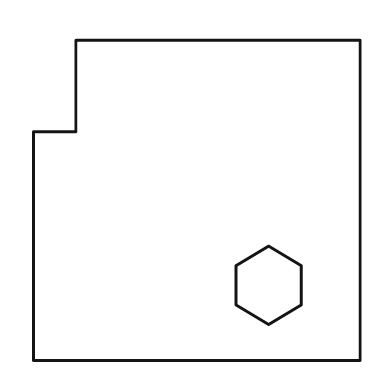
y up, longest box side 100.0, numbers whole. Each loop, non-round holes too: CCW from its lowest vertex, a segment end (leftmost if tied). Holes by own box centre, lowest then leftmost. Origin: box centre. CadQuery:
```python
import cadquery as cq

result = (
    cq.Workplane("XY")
    .moveTo(-50.0, -49.0)
    .lineTo(50.0, -49.0)
    .lineTo(50.0, 49.0)
    .lineTo(-37.0, 49.0)
    .lineTo(-37.0, 21.0)
    .lineTo(-50.0, 21.0)
    .close()
    .moveTo(22.0, -38.0)
    .lineTo(32.0, -32.0)
    .lineTo(32.0, -20.0)
    .lineTo(22.0, -14.0)
    .lineTo(12.0, -20.0)
    .lineTo(12.0, -32.0)
    .close()
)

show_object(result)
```